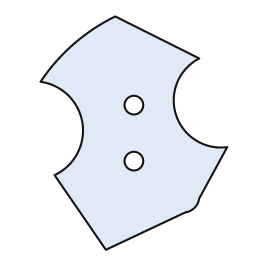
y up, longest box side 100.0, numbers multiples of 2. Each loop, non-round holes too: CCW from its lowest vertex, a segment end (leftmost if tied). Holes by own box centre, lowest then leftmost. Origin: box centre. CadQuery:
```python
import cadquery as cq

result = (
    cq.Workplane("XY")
    .moveTo(-12.0, -50.0)
    .lineTo(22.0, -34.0)
    .threePointArc((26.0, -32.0), (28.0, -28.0))
    .lineTo(40.0, -6.0)
    .threePointArc((18.0, 8.0), (28.0, 32.0))
    .lineTo(-8.0, 50.0)
    .threePointArc((-26.0, 38.0), (-40.0, 22.0))
    .threePointArc((-22.0, 4.0), (-34.0, -18.0))
    .close()
    .moveTo(0.0, -12.0)
    .circle(4.0)
    .moveTo(0.0, 12.0)
    .circle(4.0)
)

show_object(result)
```